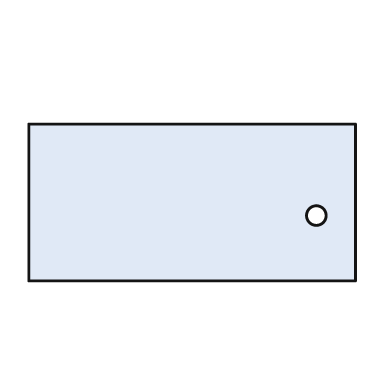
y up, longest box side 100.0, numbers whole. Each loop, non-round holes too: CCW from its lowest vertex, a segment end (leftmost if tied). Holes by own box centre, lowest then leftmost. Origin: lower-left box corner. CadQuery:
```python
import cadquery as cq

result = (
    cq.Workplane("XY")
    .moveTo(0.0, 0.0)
    .lineTo(100.0, 0.0)
    .lineTo(100.0, 48.0)
    .lineTo(0.0, 48.0)
    .close()
    .moveTo(88.0, 20.0)
    .circle(3.0)
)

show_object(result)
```